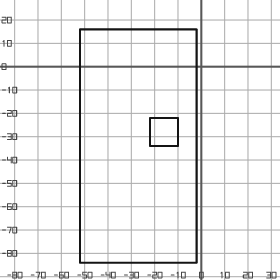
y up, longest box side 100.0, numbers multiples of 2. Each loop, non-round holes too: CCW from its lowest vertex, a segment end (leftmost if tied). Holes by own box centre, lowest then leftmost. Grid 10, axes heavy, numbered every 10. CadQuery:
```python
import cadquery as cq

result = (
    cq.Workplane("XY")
    .moveTo(-52.0, -84.0)
    .lineTo(-2.0, -84.0)
    .lineTo(-2.0, 16.0)
    .lineTo(-52.0, 16.0)
    .close()
    .moveTo(-22.0, -34.0)
    .lineTo(-10.0, -34.0)
    .lineTo(-10.0, -22.0)
    .lineTo(-22.0, -22.0)
    .close()
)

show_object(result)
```